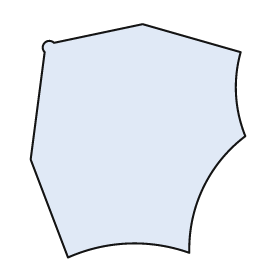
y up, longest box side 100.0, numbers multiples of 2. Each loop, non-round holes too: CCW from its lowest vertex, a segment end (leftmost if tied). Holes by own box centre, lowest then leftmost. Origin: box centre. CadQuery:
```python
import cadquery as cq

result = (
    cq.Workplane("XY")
    .moveTo(-30.0, -50.0)
    .threePointArc((-4.0, -44.0), (22.0, -48.0))
    .threePointArc((28.0, -20.0), (46.0, 2.0))
    .threePointArc((42.0, 20.0), (44.0, 38.0))
    .lineTo(2.0, 50.0)
    .lineTo(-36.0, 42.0)
    .threePointArc((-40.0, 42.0), (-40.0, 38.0))
    .lineTo(-46.0, -8.0)
    .close()
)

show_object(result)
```